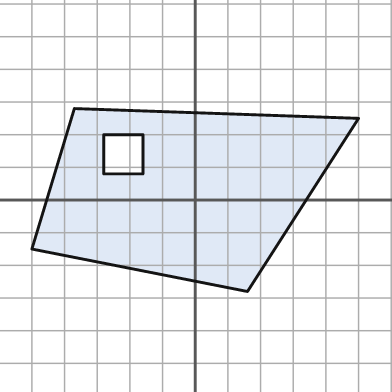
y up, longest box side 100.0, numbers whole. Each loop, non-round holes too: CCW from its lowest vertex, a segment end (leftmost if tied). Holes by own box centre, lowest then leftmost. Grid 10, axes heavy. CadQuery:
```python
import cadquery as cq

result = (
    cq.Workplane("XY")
    .moveTo(16.0, -28.0)
    .lineTo(50.0, 25.0)
    .lineTo(-37.0, 28.0)
    .lineTo(-50.0, -15.0)
    .close()
    .moveTo(-28.0, 8.0)
    .lineTo(-16.0, 8.0)
    .lineTo(-16.0, 20.0)
    .lineTo(-28.0, 20.0)
    .close()
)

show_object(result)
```